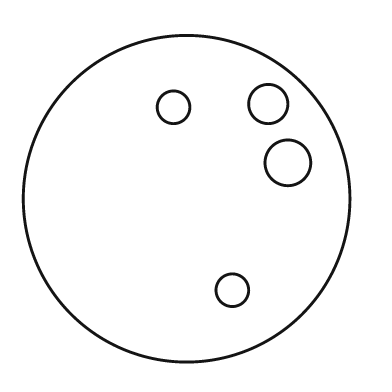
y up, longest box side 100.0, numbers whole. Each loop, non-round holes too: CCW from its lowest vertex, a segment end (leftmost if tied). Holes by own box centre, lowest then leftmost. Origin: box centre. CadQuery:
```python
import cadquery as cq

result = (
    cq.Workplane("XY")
    .moveTo(0.0, 0.0)
    .circle(50.0)
    .moveTo(14.0, -28.0)
    .circle(5.0)
    .moveTo(31.0, 11.0)
    .circle(7.0)
    .moveTo(-4.0, 28.0)
    .circle(5.0)
    .moveTo(25.0, 29.0)
    .circle(6.0)
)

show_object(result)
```